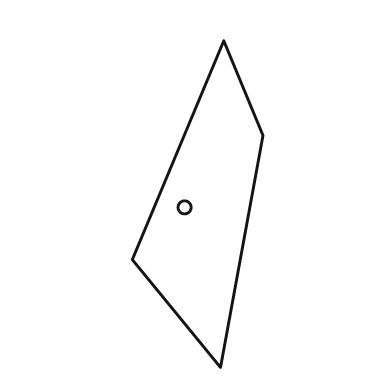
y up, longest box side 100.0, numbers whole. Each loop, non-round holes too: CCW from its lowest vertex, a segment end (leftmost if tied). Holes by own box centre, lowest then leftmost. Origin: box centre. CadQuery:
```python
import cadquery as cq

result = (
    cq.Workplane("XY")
    .moveTo(7.0, -50.0)
    .lineTo(20.0, 21.0)
    .lineTo(8.0, 50.0)
    .lineTo(-20.0, -17.0)
    .close()
    .moveTo(-4.0, -1.0)
    .circle(2.0)
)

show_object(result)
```